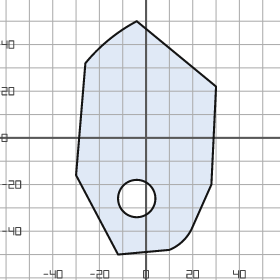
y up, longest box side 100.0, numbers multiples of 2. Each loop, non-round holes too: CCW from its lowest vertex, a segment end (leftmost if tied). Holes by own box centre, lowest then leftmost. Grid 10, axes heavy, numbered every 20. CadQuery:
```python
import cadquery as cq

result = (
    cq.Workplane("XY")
    .moveTo(-12.0, -50.0)
    .lineTo(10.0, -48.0)
    .threePointArc((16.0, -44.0), (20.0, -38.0))
    .lineTo(28.0, -20.0)
    .lineTo(30.0, 22.0)
    .lineTo(-4.0, 50.0)
    .threePointArc((-16.0, 42.0), (-26.0, 32.0))
    .lineTo(-30.0, -16.0)
    .close()
    .moveTo(-4.0, -26.0)
    .circle(8.0)
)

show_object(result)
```